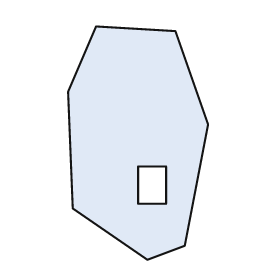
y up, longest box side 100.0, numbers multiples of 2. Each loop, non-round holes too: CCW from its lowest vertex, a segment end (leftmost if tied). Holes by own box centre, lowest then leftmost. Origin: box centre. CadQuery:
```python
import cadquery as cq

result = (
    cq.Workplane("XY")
    .moveTo(4.0, -50.0)
    .lineTo(20.0, -44.0)
    .lineTo(30.0, 8.0)
    .lineTo(16.0, 48.0)
    .lineTo(-18.0, 50.0)
    .lineTo(-30.0, 22.0)
    .lineTo(-28.0, -28.0)
    .close()
    .moveTo(0.0, -26.0)
    .lineTo(12.0, -26.0)
    .lineTo(12.0, -10.0)
    .lineTo(0.0, -10.0)
    .close()
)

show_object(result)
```